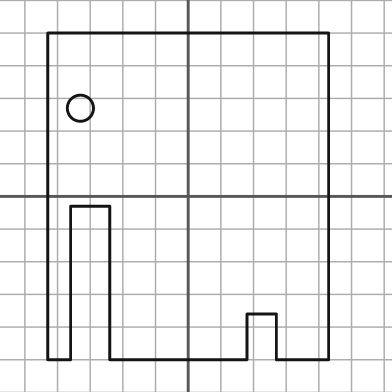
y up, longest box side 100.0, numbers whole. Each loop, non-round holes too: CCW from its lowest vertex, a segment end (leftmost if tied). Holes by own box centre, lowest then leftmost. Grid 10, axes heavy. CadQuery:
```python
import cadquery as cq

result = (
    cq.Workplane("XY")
    .moveTo(-43.0, -50.0)
    .lineTo(-36.0, -50.0)
    .lineTo(-36.0, -3.0)
    .lineTo(-24.0, -3.0)
    .lineTo(-24.0, -50.0)
    .lineTo(18.0, -50.0)
    .lineTo(18.0, -36.0)
    .lineTo(27.0, -36.0)
    .lineTo(27.0, -50.0)
    .lineTo(43.0, -50.0)
    .lineTo(43.0, 50.0)
    .lineTo(-43.0, 50.0)
    .close()
    .moveTo(-33.0, 27.0)
    .circle(4.0)
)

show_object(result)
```